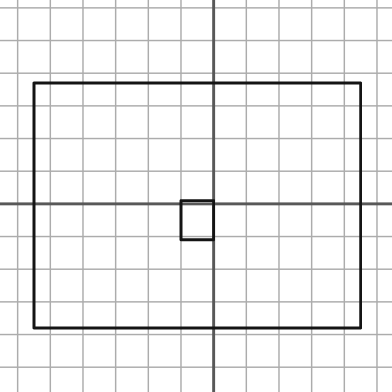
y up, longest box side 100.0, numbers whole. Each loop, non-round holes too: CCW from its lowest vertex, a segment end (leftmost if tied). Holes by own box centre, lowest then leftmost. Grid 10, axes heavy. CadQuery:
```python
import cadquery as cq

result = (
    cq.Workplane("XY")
    .moveTo(-55.0, -38.0)
    .lineTo(45.0, -38.0)
    .lineTo(45.0, 37.0)
    .lineTo(-55.0, 37.0)
    .close()
    .moveTo(-10.0, -11.0)
    .lineTo(0.0, -11.0)
    .lineTo(0.0, 1.0)
    .lineTo(-10.0, 1.0)
    .close()
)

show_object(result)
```